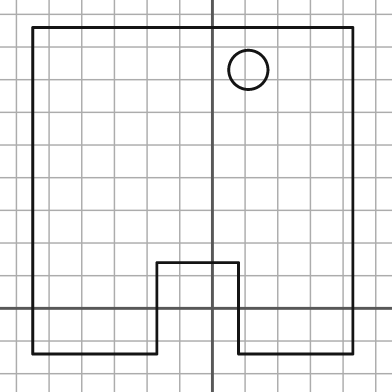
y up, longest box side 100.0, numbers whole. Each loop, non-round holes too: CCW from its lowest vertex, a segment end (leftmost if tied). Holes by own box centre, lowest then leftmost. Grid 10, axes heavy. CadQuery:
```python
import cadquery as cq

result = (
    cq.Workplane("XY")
    .moveTo(-55.0, -14.0)
    .lineTo(-17.0, -14.0)
    .lineTo(-17.0, 14.0)
    .lineTo(8.0, 14.0)
    .lineTo(8.0, -14.0)
    .lineTo(43.0, -14.0)
    .lineTo(43.0, 86.0)
    .lineTo(-55.0, 86.0)
    .close()
    .moveTo(11.0, 73.0)
    .circle(6.0)
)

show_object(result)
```